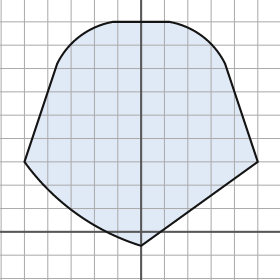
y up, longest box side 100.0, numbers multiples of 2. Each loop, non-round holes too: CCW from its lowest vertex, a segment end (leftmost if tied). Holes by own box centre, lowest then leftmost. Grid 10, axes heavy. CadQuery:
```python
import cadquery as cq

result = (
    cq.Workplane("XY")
    .moveTo(0.0, -6.0)
    .lineTo(50.0, 30.0)
    .lineTo(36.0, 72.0)
    .threePointArc((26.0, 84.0), (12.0, 90.0))
    .lineTo(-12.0, 90.0)
    .threePointArc((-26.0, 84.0), (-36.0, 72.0))
    .lineTo(-50.0, 30.0)
    .threePointArc((-28.0, 8.0), (0.0, -6.0))
    .close()
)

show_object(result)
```